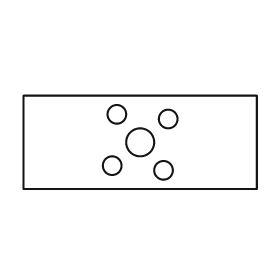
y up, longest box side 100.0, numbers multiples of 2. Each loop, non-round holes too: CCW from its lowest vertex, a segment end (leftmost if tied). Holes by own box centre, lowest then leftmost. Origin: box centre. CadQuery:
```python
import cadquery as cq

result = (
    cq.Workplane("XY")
    .moveTo(-50.0, -20.0)
    .lineTo(50.0, -20.0)
    .lineTo(50.0, 20.0)
    .lineTo(-50.0, 20.0)
    .close()
    .moveTo(10.0, -12.0)
    .circle(4.0)
    .moveTo(-12.0, -10.0)
    .circle(4.0)
    .moveTo(0.0, 0.0)
    .circle(6.0)
    .moveTo(12.0, 10.0)
    .circle(4.0)
    .moveTo(-10.0, 12.0)
    .circle(4.0)
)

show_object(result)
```